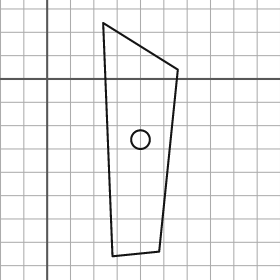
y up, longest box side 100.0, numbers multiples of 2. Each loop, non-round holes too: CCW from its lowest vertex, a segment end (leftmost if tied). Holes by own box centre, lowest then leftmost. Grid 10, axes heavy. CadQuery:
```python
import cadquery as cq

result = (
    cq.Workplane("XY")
    .moveTo(28.0, -76.0)
    .lineTo(48.0, -74.0)
    .lineTo(56.0, 4.0)
    .lineTo(24.0, 24.0)
    .close()
    .moveTo(40.0, -26.0)
    .circle(4.0)
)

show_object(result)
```